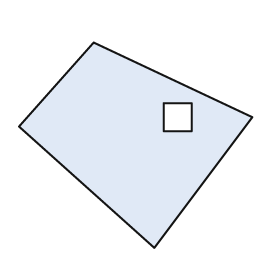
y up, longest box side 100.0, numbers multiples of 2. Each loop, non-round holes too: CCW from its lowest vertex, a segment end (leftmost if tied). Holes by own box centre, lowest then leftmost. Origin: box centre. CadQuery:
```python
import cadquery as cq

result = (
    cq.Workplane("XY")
    .moveTo(8.0, -44.0)
    .lineTo(50.0, 12.0)
    .lineTo(-18.0, 44.0)
    .lineTo(-50.0, 8.0)
    .close()
    .moveTo(12.0, 6.0)
    .lineTo(24.0, 6.0)
    .lineTo(24.0, 18.0)
    .lineTo(12.0, 18.0)
    .close()
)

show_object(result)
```